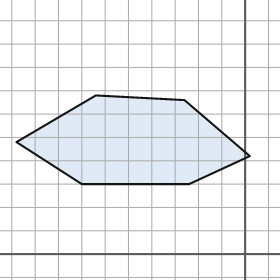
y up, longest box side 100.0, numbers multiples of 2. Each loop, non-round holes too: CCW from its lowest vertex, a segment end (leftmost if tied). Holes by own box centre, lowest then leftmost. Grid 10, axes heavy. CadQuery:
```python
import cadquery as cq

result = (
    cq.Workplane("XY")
    .moveTo(-70.0, 30.0)
    .lineTo(-24.0, 30.0)
    .lineTo(2.0, 42.0)
    .lineTo(-26.0, 66.0)
    .lineTo(-64.0, 68.0)
    .lineTo(-98.0, 48.0)
    .close()
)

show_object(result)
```